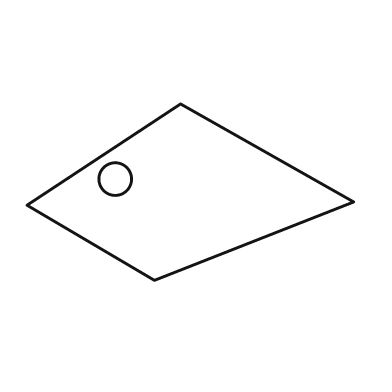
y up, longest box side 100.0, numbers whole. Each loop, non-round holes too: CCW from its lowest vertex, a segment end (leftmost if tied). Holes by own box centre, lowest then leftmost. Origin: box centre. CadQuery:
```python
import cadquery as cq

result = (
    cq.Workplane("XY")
    .moveTo(-11.0, -27.0)
    .lineTo(50.0, -3.0)
    .lineTo(-3.0, 27.0)
    .lineTo(-50.0, -4.0)
    .close()
    .moveTo(-23.0, 4.0)
    .circle(5.0)
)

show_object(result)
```